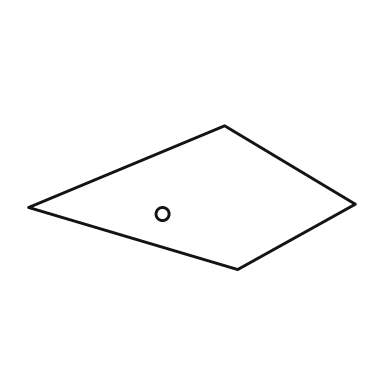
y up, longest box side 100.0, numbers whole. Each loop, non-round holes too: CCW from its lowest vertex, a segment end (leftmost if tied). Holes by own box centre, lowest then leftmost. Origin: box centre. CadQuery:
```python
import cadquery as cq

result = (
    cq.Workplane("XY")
    .moveTo(14.0, -22.0)
    .lineTo(50.0, -2.0)
    .lineTo(10.0, 22.0)
    .lineTo(-50.0, -3.0)
    .close()
    .moveTo(-9.0, -5.0)
    .circle(2.0)
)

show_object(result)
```